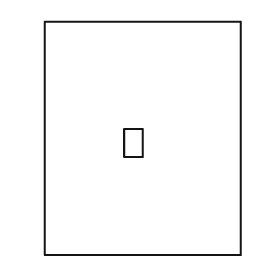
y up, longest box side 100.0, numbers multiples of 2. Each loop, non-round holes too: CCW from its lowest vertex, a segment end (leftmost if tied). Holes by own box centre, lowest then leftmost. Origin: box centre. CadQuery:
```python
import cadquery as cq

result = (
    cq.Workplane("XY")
    .moveTo(-42.0, -50.0)
    .lineTo(42.0, -50.0)
    .lineTo(42.0, 50.0)
    .lineTo(-42.0, 50.0)
    .close()
    .moveTo(-8.0, -8.0)
    .lineTo(0.0, -8.0)
    .lineTo(0.0, 4.0)
    .lineTo(-8.0, 4.0)
    .close()
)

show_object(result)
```